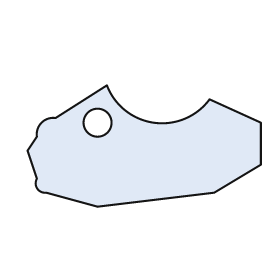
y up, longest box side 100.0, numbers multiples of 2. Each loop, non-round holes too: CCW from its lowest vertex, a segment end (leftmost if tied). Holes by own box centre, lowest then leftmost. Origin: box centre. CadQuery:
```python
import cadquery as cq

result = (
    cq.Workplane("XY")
    .moveTo(-20.0, -26.0)
    .lineTo(30.0, -20.0)
    .lineTo(50.0, -8.0)
    .lineTo(50.0, 10.0)
    .lineTo(28.0, 20.0)
    .threePointArc((4.0, 10.0), (-16.0, 26.0))
    .lineTo(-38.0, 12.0)
    .threePointArc((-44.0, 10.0), (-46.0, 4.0))
    .lineTo(-50.0, -2.0)
    .lineTo(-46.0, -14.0)
    .threePointArc((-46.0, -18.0), (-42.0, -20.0))
    .close()
    .moveTo(-20.0, 10.0)
    .circle(6.0)
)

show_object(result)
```